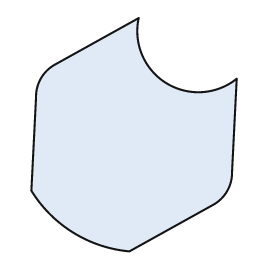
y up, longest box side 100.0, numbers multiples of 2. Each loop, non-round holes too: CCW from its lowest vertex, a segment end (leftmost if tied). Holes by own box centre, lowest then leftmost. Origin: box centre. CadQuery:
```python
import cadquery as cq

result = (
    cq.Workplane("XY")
    .moveTo(-2.0, -50.0)
    .lineTo(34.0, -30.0)
    .threePointArc((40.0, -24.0), (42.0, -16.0))
    .lineTo(44.0, 24.0)
    .threePointArc((14.0, 22.0), (2.0, 50.0))
    .lineTo(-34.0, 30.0)
    .threePointArc((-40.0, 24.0), (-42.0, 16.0))
    .lineTo(-44.0, -24.0)
    .threePointArc((-26.0, -42.0), (-2.0, -50.0))
    .close()
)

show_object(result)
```